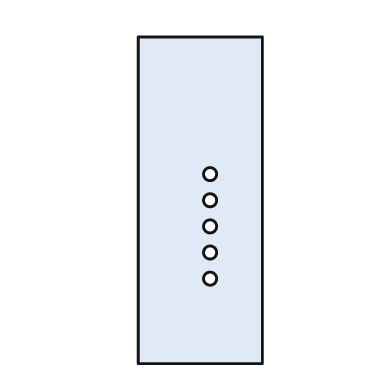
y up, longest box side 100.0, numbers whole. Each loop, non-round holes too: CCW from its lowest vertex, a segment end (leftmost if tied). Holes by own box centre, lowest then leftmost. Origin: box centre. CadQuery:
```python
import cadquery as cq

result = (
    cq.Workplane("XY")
    .moveTo(-19.0, -50.0)
    .lineTo(19.0, -50.0)
    .lineTo(19.0, 50.0)
    .lineTo(-19.0, 50.0)
    .close()
    .moveTo(3.0, -24.0)
    .circle(2.0)
    .moveTo(3.0, -16.0)
    .circle(2.0)
    .moveTo(3.0, -8.0)
    .circle(2.0)
    .moveTo(3.0, 0.0)
    .circle(2.0)
    .moveTo(3.0, 8.0)
    .circle(2.0)
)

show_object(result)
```